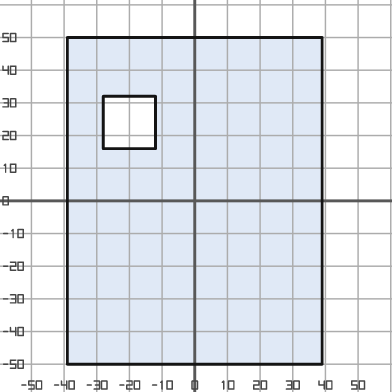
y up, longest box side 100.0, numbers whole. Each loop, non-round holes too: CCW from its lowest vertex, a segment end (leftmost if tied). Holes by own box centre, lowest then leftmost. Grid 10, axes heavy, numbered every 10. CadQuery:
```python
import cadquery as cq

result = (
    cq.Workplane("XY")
    .moveTo(-39.0, -50.0)
    .lineTo(39.0, -50.0)
    .lineTo(39.0, 50.0)
    .lineTo(-39.0, 50.0)
    .close()
    .moveTo(-28.0, 16.0)
    .lineTo(-12.0, 16.0)
    .lineTo(-12.0, 32.0)
    .lineTo(-28.0, 32.0)
    .close()
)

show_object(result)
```